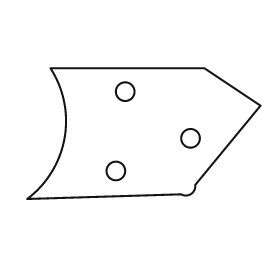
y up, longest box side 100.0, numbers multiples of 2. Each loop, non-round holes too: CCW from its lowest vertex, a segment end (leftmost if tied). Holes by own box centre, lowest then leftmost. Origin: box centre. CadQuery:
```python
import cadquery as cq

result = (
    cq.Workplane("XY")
    .moveTo(-50.0, -28.0)
    .lineTo(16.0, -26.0)
    .threePointArc((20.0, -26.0), (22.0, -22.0))
    .lineTo(50.0, 12.0)
    .lineTo(26.0, 28.0)
    .lineTo(-40.0, 28.0)
    .threePointArc((-34.0, -2.0), (-50.0, -28.0))
    .close()
    .moveTo(-12.0, -16.0)
    .circle(4.0)
    .moveTo(20.0, -2.0)
    .circle(4.0)
    .moveTo(-8.0, 18.0)
    .circle(4.0)
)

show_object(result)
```